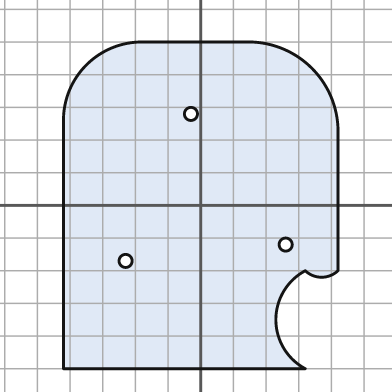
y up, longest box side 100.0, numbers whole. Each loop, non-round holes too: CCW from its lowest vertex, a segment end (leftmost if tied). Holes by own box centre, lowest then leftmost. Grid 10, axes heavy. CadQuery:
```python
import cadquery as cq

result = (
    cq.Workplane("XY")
    .moveTo(-42.0, -50.0)
    .lineTo(32.0, -50.0)
    .threePointArc((23.0, -35.0), (32.0, -20.0))
    .threePointArc((37.0, -22.0), (42.0, -20.0))
    .lineTo(42.0, 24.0)
    .threePointArc((34.0, 42.0), (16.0, 50.0))
    .lineTo(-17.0, 50.0)
    .threePointArc((-35.0, 43.0), (-42.0, 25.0))
    .close()
    .moveTo(-23.0, -17.0)
    .circle(2.0)
    .moveTo(26.0, -12.0)
    .circle(2.0)
    .moveTo(-3.0, 28.0)
    .circle(2.0)
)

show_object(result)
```